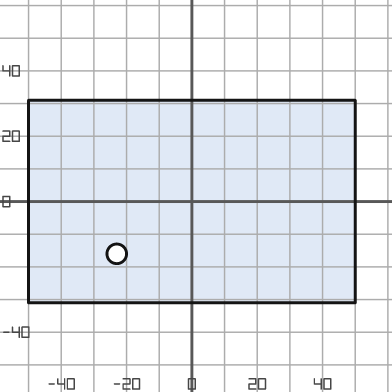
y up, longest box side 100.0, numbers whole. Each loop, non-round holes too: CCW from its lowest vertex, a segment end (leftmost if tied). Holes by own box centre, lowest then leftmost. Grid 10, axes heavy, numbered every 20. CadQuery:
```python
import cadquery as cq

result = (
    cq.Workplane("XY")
    .moveTo(-50.0, -31.0)
    .lineTo(50.0, -31.0)
    .lineTo(50.0, 31.0)
    .lineTo(-50.0, 31.0)
    .close()
    .moveTo(-23.0, -16.0)
    .circle(3.0)
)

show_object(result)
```